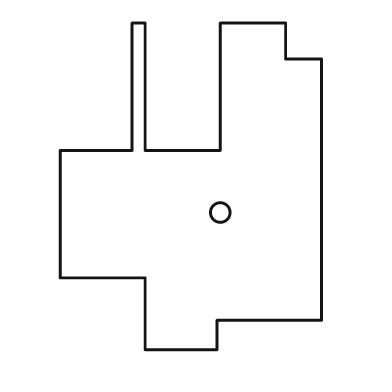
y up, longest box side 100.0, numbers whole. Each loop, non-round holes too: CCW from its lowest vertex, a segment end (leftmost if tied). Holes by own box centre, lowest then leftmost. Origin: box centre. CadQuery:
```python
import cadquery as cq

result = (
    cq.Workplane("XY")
    .moveTo(-14.0, -50.0)
    .lineTo(8.0, -50.0)
    .lineTo(8.0, -41.0)
    .lineTo(40.0, -41.0)
    .lineTo(40.0, 39.0)
    .lineTo(29.0, 39.0)
    .lineTo(29.0, 50.0)
    .lineTo(9.0, 50.0)
    .lineTo(9.0, 11.0)
    .lineTo(-14.0, 11.0)
    .lineTo(-14.0, 50.0)
    .lineTo(-18.0, 50.0)
    .lineTo(-18.0, 11.0)
    .lineTo(-40.0, 11.0)
    .lineTo(-40.0, -28.0)
    .lineTo(-14.0, -28.0)
    .close()
    .moveTo(9.0, -8.0)
    .circle(3.0)
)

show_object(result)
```